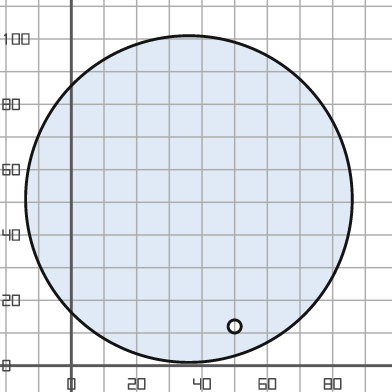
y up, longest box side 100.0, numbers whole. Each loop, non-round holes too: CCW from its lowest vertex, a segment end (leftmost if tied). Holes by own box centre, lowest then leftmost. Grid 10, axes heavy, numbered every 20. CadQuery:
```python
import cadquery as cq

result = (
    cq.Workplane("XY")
    .moveTo(36.0, 51.0)
    .circle(50.0)
    .moveTo(50.0, 12.0)
    .circle(2.0)
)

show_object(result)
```